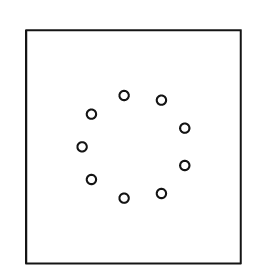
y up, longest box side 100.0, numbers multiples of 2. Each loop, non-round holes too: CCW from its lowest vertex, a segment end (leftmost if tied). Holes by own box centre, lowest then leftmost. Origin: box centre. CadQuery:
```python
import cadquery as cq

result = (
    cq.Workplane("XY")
    .moveTo(-46.0, -50.0)
    .lineTo(46.0, -50.0)
    .lineTo(46.0, 50.0)
    .lineTo(-46.0, 50.0)
    .close()
    .moveTo(-4.0, -22.0)
    .circle(2.0)
    .moveTo(12.0, -20.0)
    .circle(2.0)
    .moveTo(-18.0, -14.0)
    .circle(2.0)
    .moveTo(22.0, -8.0)
    .circle(2.0)
    .moveTo(-22.0, 0.0)
    .circle(2.0)
    .moveTo(22.0, 8.0)
    .circle(2.0)
    .moveTo(-18.0, 14.0)
    .circle(2.0)
    .moveTo(12.0, 20.0)
    .circle(2.0)
    .moveTo(-4.0, 22.0)
    .circle(2.0)
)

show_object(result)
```